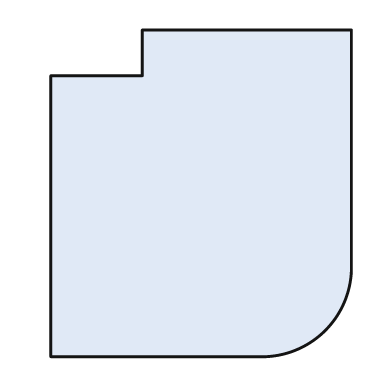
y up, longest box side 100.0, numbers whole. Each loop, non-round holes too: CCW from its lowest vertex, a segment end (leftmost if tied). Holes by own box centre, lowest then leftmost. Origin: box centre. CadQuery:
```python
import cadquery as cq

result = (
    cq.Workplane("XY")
    .moveTo(-46.0, -50.0)
    .lineTo(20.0, -50.0)
    .threePointArc((38.0, -42.0), (46.0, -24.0))
    .lineTo(46.0, 50.0)
    .lineTo(-18.0, 50.0)
    .lineTo(-18.0, 36.0)
    .lineTo(-46.0, 36.0)
    .close()
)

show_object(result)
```